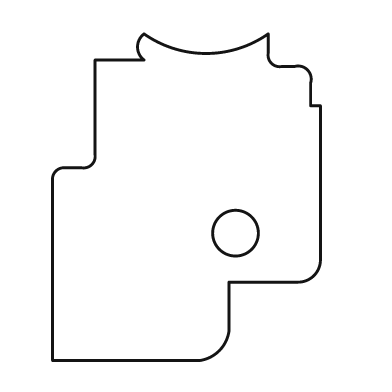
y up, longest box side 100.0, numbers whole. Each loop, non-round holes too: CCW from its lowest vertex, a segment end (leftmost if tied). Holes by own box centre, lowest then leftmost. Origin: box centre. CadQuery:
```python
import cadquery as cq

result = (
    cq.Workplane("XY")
    .moveTo(-41.0, -50.0)
    .lineTo(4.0, -50.0)
    .threePointArc((10.0, -47.0), (13.0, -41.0))
    .lineTo(13.0, -26.0)
    .lineTo(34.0, -26.0)
    .threePointArc((39.0, -24.0), (41.0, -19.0))
    .lineTo(41.0, 28.0)
    .lineTo(38.0, 28.0)
    .lineTo(38.0, 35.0)
    .threePointArc((37.0, 39.0), (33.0, 40.0))
    .lineTo(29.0, 40.0)
    .threePointArc((26.0, 41.0), (25.0, 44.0))
    .lineTo(25.0, 50.0)
    .threePointArc((6.0, 44.0), (-13.0, 50.0))
    .threePointArc((-15.0, 46.0), (-13.0, 42.0))
    .lineTo(-28.0, 42.0)
    .lineTo(-28.0, 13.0)
    .threePointArc((-29.0, 10.0), (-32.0, 9.0))
    .lineTo(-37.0, 9.0)
    .threePointArc((-40.0, 8.0), (-41.0, 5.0))
    .close()
    .moveTo(15.0, -11.0)
    .circle(7.0)
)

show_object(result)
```